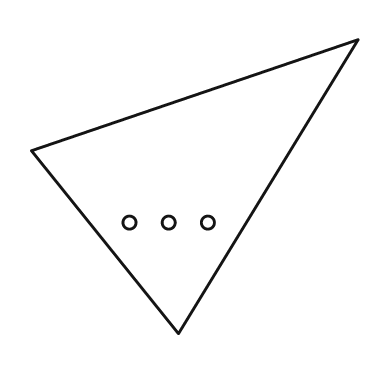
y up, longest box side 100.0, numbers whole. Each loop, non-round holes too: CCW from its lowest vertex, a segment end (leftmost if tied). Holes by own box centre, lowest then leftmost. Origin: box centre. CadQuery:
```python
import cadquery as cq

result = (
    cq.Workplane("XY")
    .moveTo(-5.0, -45.0)
    .lineTo(50.0, 45.0)
    .lineTo(-50.0, 11.0)
    .close()
    .moveTo(-20.0, -11.0)
    .circle(2.0)
    .moveTo(-8.0, -11.0)
    .circle(2.0)
    .moveTo(4.0, -11.0)
    .circle(2.0)
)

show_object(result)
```